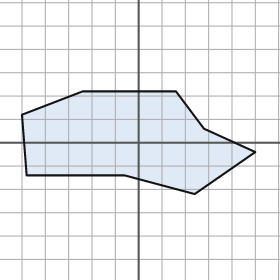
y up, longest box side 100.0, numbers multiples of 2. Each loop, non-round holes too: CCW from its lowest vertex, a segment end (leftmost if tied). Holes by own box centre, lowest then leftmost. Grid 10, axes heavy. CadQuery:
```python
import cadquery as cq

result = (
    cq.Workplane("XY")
    .moveTo(24.0, -22.0)
    .lineTo(50.0, -4.0)
    .lineTo(28.0, 6.0)
    .lineTo(16.0, 22.0)
    .lineTo(-24.0, 22.0)
    .lineTo(-50.0, 12.0)
    .lineTo(-48.0, -14.0)
    .lineTo(-6.0, -14.0)
    .close()
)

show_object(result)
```